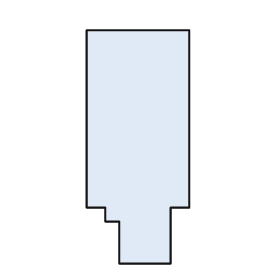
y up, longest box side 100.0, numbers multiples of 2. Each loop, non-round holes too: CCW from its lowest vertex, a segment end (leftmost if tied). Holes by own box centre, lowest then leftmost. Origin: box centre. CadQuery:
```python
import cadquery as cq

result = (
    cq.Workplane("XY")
    .moveTo(-8.0, -50.0)
    .lineTo(14.0, -50.0)
    .lineTo(14.0, -26.0)
    .lineTo(22.0, -26.0)
    .lineTo(22.0, 50.0)
    .lineTo(-22.0, 50.0)
    .lineTo(-22.0, -26.0)
    .lineTo(-14.0, -26.0)
    .lineTo(-14.0, -32.0)
    .lineTo(-8.0, -32.0)
    .close()
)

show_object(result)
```